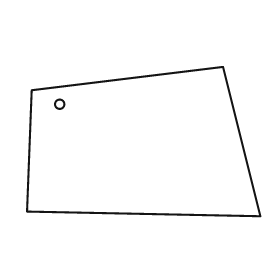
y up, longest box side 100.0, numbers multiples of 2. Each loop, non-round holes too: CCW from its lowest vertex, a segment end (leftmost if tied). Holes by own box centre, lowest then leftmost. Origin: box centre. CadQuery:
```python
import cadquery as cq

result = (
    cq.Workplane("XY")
    .moveTo(50.0, -32.0)
    .lineTo(34.0, 32.0)
    .lineTo(-48.0, 22.0)
    .lineTo(-50.0, -30.0)
    .close()
    .moveTo(-36.0, 16.0)
    .circle(2.0)
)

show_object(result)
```